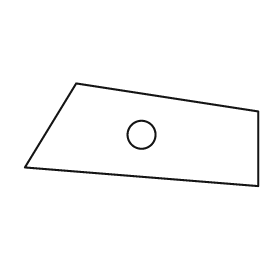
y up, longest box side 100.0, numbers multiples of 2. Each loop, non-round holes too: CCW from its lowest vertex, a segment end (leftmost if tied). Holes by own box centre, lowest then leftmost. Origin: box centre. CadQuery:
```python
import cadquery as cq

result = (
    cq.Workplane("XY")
    .moveTo(50.0, -22.0)
    .lineTo(50.0, 10.0)
    .lineTo(-28.0, 22.0)
    .lineTo(-50.0, -14.0)
    .close()
    .moveTo(0.0, 0.0)
    .circle(6.0)
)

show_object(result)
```